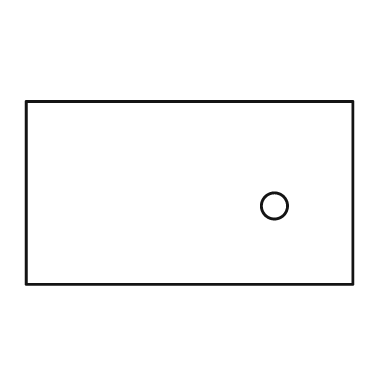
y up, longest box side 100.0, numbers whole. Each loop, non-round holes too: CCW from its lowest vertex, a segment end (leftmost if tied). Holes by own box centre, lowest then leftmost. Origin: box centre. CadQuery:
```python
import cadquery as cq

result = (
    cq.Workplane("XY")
    .moveTo(-50.0, -28.0)
    .lineTo(50.0, -28.0)
    .lineTo(50.0, 28.0)
    .lineTo(-50.0, 28.0)
    .close()
    .moveTo(26.0, -4.0)
    .circle(4.0)
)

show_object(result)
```